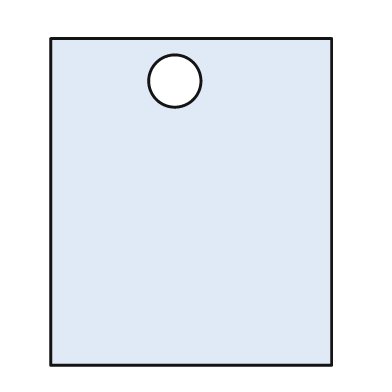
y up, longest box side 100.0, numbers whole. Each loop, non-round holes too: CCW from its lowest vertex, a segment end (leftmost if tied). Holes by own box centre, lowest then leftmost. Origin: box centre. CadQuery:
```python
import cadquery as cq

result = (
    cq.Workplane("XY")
    .moveTo(-43.0, -50.0)
    .lineTo(43.0, -50.0)
    .lineTo(43.0, 50.0)
    .lineTo(-43.0, 50.0)
    .close()
    .moveTo(-5.0, 37.0)
    .circle(8.0)
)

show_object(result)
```